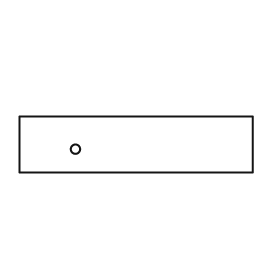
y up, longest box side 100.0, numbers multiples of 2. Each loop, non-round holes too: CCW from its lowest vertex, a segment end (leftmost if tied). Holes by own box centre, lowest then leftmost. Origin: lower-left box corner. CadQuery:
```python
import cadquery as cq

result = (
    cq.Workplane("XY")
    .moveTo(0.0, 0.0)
    .lineTo(100.0, 0.0)
    .lineTo(100.0, 24.0)
    .lineTo(0.0, 24.0)
    .close()
    .moveTo(24.0, 10.0)
    .circle(2.0)
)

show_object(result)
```